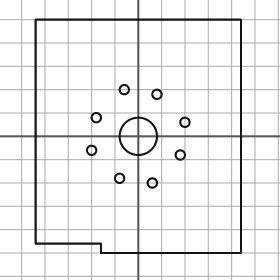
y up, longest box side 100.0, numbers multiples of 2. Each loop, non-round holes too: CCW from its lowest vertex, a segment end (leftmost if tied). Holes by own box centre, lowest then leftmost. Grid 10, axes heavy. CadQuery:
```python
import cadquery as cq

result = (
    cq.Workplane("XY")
    .moveTo(-16.0, -50.0)
    .lineTo(44.0, -50.0)
    .lineTo(44.0, 50.0)
    .lineTo(-44.0, 50.0)
    .lineTo(-44.0, -46.0)
    .lineTo(-16.0, -46.0)
    .close()
    .moveTo(6.0, -20.0)
    .circle(2.0)
    .moveTo(-8.0, -18.0)
    .circle(2.0)
    .moveTo(18.0, -8.0)
    .circle(2.0)
    .moveTo(-20.0, -6.0)
    .circle(2.0)
    .moveTo(0.0, 0.0)
    .circle(8.0)
    .moveTo(20.0, 6.0)
    .circle(2.0)
    .moveTo(-18.0, 8.0)
    .circle(2.0)
    .moveTo(8.0, 18.0)
    .circle(2.0)
    .moveTo(-6.0, 20.0)
    .circle(2.0)
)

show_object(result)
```